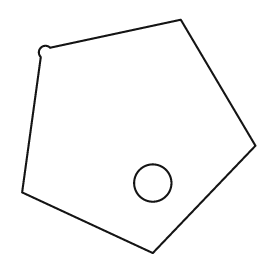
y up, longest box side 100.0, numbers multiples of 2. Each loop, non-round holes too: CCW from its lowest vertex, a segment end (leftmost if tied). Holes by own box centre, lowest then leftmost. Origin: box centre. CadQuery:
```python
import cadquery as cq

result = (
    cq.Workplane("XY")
    .moveTo(6.0, -50.0)
    .lineTo(50.0, -4.0)
    .lineTo(18.0, 50.0)
    .lineTo(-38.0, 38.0)
    .threePointArc((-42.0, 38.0), (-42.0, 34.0))
    .lineTo(-50.0, -24.0)
    .close()
    .moveTo(6.0, -20.0)
    .circle(8.0)
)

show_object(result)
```